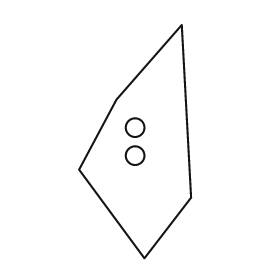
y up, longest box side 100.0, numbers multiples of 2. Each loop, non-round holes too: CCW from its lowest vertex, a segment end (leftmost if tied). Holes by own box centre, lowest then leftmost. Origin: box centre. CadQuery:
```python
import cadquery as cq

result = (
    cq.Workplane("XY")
    .moveTo(4.0, -50.0)
    .lineTo(24.0, -24.0)
    .lineTo(20.0, 50.0)
    .lineTo(-8.0, 18.0)
    .lineTo(-24.0, -12.0)
    .close()
    .moveTo(0.0, -6.0)
    .circle(4.0)
    .moveTo(0.0, 6.0)
    .circle(4.0)
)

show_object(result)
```